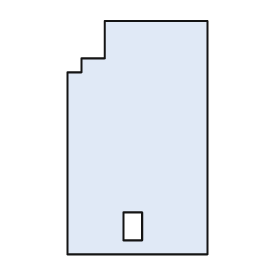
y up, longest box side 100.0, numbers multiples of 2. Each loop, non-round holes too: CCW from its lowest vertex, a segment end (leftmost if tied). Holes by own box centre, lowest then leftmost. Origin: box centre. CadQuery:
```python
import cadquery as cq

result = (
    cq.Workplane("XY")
    .moveTo(-30.0, -50.0)
    .lineTo(30.0, -50.0)
    .lineTo(30.0, 50.0)
    .lineTo(-14.0, 50.0)
    .lineTo(-14.0, 34.0)
    .lineTo(-24.0, 34.0)
    .lineTo(-24.0, 28.0)
    .lineTo(-30.0, 28.0)
    .close()
    .moveTo(-6.0, -44.0)
    .lineTo(2.0, -44.0)
    .lineTo(2.0, -32.0)
    .lineTo(-6.0, -32.0)
    .close()
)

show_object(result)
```